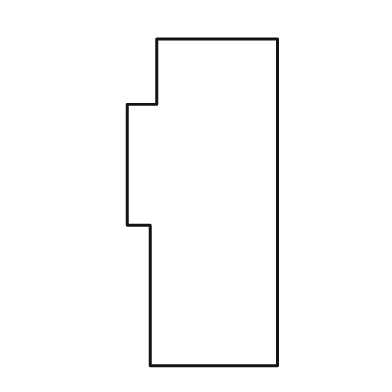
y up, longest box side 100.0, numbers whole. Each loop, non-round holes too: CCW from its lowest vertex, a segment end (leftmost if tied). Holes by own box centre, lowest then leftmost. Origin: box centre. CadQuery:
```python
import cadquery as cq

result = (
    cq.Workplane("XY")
    .moveTo(-16.0, -50.0)
    .lineTo(23.0, -50.0)
    .lineTo(23.0, 50.0)
    .lineTo(-14.0, 50.0)
    .lineTo(-14.0, 30.0)
    .lineTo(-23.0, 30.0)
    .lineTo(-23.0, -7.0)
    .lineTo(-16.0, -7.0)
    .close()
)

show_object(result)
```